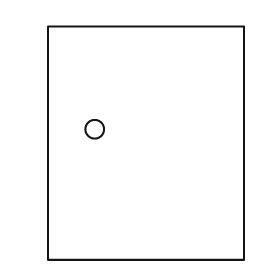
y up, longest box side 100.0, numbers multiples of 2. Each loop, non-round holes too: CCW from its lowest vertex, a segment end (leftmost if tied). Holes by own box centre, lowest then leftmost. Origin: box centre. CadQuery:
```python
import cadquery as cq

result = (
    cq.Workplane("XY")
    .moveTo(-42.0, -50.0)
    .lineTo(42.0, -50.0)
    .lineTo(42.0, 50.0)
    .lineTo(-42.0, 50.0)
    .close()
    .moveTo(-22.0, 6.0)
    .circle(4.0)
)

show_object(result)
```